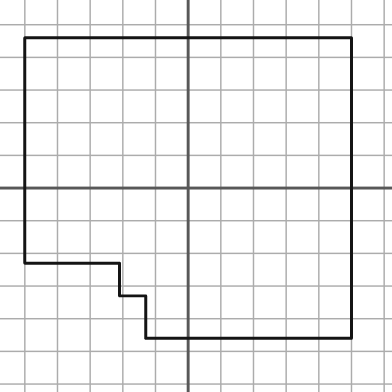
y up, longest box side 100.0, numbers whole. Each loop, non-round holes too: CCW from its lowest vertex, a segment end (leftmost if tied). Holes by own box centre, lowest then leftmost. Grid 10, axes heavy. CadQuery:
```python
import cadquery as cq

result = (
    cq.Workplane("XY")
    .moveTo(-13.0, -46.0)
    .lineTo(50.0, -46.0)
    .lineTo(50.0, 46.0)
    .lineTo(-50.0, 46.0)
    .lineTo(-50.0, -23.0)
    .lineTo(-21.0, -23.0)
    .lineTo(-21.0, -33.0)
    .lineTo(-13.0, -33.0)
    .close()
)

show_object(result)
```